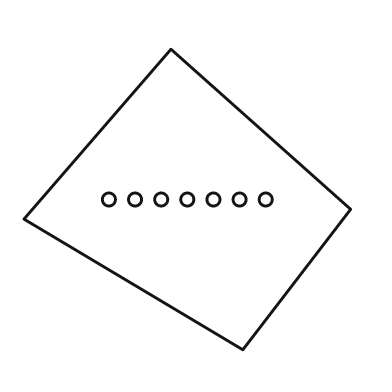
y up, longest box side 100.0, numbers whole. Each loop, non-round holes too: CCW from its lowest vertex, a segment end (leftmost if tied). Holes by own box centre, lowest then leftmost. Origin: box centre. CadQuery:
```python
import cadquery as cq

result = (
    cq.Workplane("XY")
    .moveTo(17.0, -46.0)
    .lineTo(50.0, -3.0)
    .lineTo(-5.0, 46.0)
    .lineTo(-50.0, -6.0)
    .close()
    .moveTo(-24.0, 0.0)
    .circle(2.0)
    .moveTo(-16.0, 0.0)
    .circle(2.0)
    .moveTo(-8.0, 0.0)
    .circle(2.0)
    .moveTo(0.0, 0.0)
    .circle(2.0)
    .moveTo(8.0, 0.0)
    .circle(2.0)
    .moveTo(16.0, 0.0)
    .circle(2.0)
    .moveTo(24.0, 0.0)
    .circle(2.0)
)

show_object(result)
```